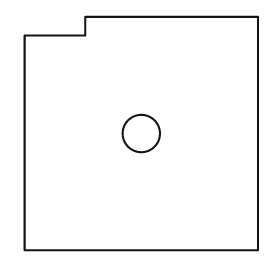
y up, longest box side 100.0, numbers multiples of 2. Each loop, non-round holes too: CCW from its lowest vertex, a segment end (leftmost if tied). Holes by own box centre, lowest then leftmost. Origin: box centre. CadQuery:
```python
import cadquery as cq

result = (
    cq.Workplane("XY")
    .moveTo(-50.0, -50.0)
    .lineTo(50.0, -50.0)
    .lineTo(50.0, 50.0)
    .lineTo(-24.0, 50.0)
    .lineTo(-24.0, 42.0)
    .lineTo(-50.0, 42.0)
    .close()
    .moveTo(0.0, 0.0)
    .circle(8.0)
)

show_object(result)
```